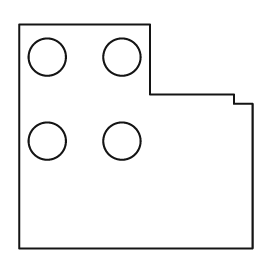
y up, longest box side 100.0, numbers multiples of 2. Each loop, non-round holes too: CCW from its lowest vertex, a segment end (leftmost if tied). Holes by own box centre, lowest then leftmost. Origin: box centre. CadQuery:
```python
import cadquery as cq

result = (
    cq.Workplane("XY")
    .moveTo(-50.0, -48.0)
    .lineTo(50.0, -48.0)
    .lineTo(50.0, 14.0)
    .lineTo(42.0, 14.0)
    .lineTo(42.0, 18.0)
    .lineTo(6.0, 18.0)
    .lineTo(6.0, 48.0)
    .lineTo(-50.0, 48.0)
    .close()
    .moveTo(-38.0, -2.0)
    .circle(8.0)
    .moveTo(-6.0, -2.0)
    .circle(8.0)
    .moveTo(-38.0, 34.0)
    .circle(8.0)
    .moveTo(-6.0, 34.0)
    .circle(8.0)
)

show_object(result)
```